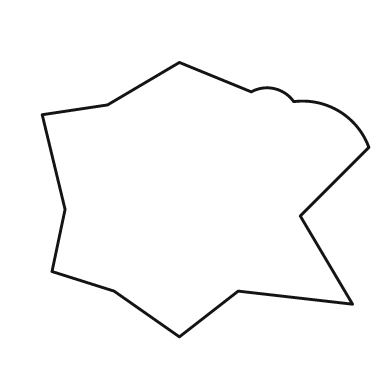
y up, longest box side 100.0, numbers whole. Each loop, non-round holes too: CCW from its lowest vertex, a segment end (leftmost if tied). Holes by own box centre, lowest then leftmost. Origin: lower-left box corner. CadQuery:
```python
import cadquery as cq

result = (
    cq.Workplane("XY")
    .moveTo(42.0, 0.0)
    .lineTo(60.0, 14.0)
    .lineTo(95.0, 10.0)
    .lineTo(79.0, 37.0)
    .lineTo(100.0, 58.0)
    .threePointArc((91.0, 69.0), (77.0, 72.0))
    .threePointArc((71.0, 76.0), (64.0, 75.0))
    .lineTo(42.0, 84.0)
    .lineTo(20.0, 71.0)
    .lineTo(0.0, 68.0)
    .lineTo(7.0, 39.0)
    .lineTo(3.0, 20.0)
    .lineTo(22.0, 14.0)
    .close()
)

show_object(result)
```